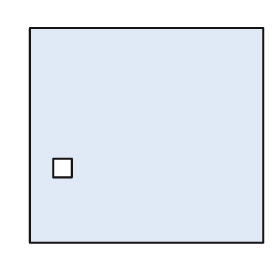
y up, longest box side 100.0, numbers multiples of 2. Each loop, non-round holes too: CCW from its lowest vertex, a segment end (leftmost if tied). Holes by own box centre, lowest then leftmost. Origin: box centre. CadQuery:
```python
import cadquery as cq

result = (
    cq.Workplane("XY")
    .moveTo(-50.0, -46.0)
    .lineTo(50.0, -46.0)
    .lineTo(50.0, 46.0)
    .lineTo(-50.0, 46.0)
    .close()
    .moveTo(-40.0, -18.0)
    .lineTo(-32.0, -18.0)
    .lineTo(-32.0, -10.0)
    .lineTo(-40.0, -10.0)
    .close()
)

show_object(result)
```